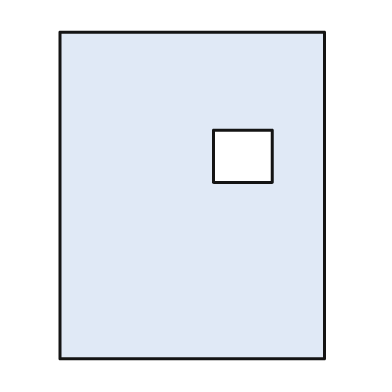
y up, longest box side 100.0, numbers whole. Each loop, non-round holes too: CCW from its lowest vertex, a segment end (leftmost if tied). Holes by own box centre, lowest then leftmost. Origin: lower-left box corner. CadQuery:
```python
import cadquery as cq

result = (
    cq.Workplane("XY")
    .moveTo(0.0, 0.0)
    .lineTo(81.0, 0.0)
    .lineTo(81.0, 100.0)
    .lineTo(0.0, 100.0)
    .close()
    .moveTo(47.0, 54.0)
    .lineTo(65.0, 54.0)
    .lineTo(65.0, 70.0)
    .lineTo(47.0, 70.0)
    .close()
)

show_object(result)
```